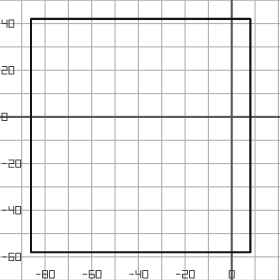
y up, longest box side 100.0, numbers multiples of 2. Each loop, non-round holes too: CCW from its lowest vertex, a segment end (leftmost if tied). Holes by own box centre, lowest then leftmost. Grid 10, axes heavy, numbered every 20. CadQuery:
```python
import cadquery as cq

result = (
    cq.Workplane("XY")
    .moveTo(-86.0, -58.0)
    .lineTo(8.0, -58.0)
    .lineTo(8.0, 42.0)
    .lineTo(-86.0, 42.0)
    .close()
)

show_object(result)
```